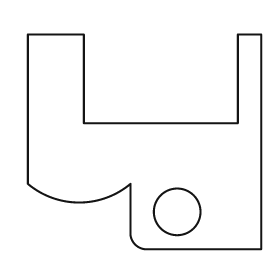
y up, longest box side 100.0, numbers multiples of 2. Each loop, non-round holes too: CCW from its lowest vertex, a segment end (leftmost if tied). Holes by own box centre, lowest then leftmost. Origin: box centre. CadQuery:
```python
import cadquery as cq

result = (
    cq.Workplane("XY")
    .moveTo(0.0, -46.0)
    .lineTo(50.0, -46.0)
    .lineTo(50.0, 46.0)
    .lineTo(40.0, 46.0)
    .lineTo(40.0, 8.0)
    .lineTo(-26.0, 8.0)
    .lineTo(-26.0, 46.0)
    .lineTo(-50.0, 46.0)
    .lineTo(-50.0, -18.0)
    .threePointArc((-28.0, -26.0), (-6.0, -18.0))
    .lineTo(-6.0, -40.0)
    .threePointArc((-4.0, -44.0), (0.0, -46.0))
    .close()
    .moveTo(14.0, -30.0)
    .circle(10.0)
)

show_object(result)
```